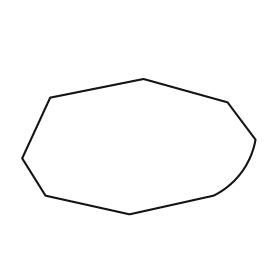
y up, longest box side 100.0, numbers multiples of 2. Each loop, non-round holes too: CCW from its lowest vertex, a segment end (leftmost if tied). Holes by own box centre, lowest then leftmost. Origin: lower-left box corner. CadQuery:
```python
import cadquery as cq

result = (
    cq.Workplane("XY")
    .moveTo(46.0, 0.0)
    .lineTo(82.0, 8.0)
    .threePointArc((94.0, 18.0), (100.0, 32.0))
    .lineTo(88.0, 48.0)
    .lineTo(52.0, 58.0)
    .lineTo(12.0, 50.0)
    .lineTo(0.0, 24.0)
    .lineTo(10.0, 8.0)
    .close()
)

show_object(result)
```